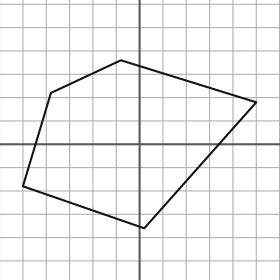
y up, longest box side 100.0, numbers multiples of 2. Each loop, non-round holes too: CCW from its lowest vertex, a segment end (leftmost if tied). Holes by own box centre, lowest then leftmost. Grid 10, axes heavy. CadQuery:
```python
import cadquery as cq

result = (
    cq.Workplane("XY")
    .moveTo(2.0, -36.0)
    .lineTo(50.0, 18.0)
    .lineTo(-8.0, 36.0)
    .lineTo(-38.0, 22.0)
    .lineTo(-50.0, -18.0)
    .close()
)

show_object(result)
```